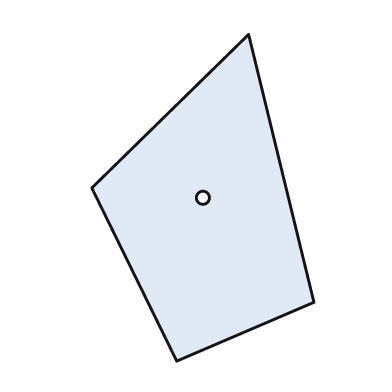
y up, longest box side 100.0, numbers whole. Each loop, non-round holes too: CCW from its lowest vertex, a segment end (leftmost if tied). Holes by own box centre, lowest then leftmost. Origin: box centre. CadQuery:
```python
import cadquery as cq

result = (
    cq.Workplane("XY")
    .moveTo(-8.0, -50.0)
    .lineTo(34.0, -32.0)
    .lineTo(14.0, 50.0)
    .lineTo(-34.0, 3.0)
    .close()
    .moveTo(0.0, 0.0)
    .circle(2.0)
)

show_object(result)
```